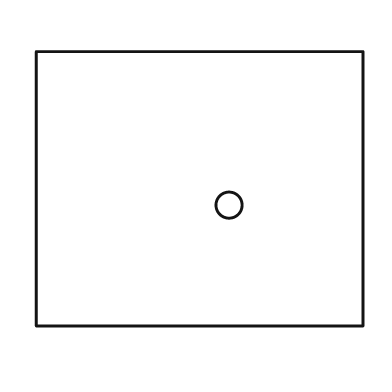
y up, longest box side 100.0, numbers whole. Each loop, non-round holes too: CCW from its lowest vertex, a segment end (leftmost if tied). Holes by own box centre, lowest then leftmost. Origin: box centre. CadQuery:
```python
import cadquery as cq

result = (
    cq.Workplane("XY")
    .moveTo(-50.0, -42.0)
    .lineTo(50.0, -42.0)
    .lineTo(50.0, 42.0)
    .lineTo(-50.0, 42.0)
    .close()
    .moveTo(9.0, -5.0)
    .circle(4.0)
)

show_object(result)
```